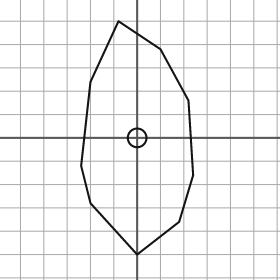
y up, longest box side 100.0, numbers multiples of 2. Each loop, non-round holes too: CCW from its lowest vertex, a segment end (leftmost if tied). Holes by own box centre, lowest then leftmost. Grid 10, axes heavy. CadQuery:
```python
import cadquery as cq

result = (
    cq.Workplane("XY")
    .moveTo(0.0, -50.0)
    .lineTo(18.0, -36.0)
    .lineTo(24.0, -16.0)
    .lineTo(22.0, 16.0)
    .lineTo(10.0, 38.0)
    .lineTo(-8.0, 50.0)
    .lineTo(-20.0, 24.0)
    .lineTo(-24.0, -12.0)
    .lineTo(-20.0, -28.0)
    .close()
    .moveTo(0.0, 0.0)
    .circle(4.0)
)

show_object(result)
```